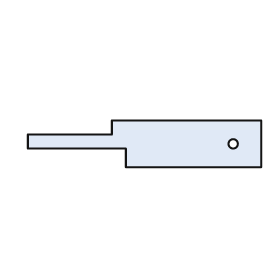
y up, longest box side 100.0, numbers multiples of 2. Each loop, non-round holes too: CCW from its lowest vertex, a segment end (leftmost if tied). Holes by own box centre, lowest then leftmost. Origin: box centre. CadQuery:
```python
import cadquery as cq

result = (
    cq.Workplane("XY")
    .moveTo(-8.0, -10.0)
    .lineTo(50.0, -10.0)
    .lineTo(50.0, 10.0)
    .lineTo(-14.0, 10.0)
    .lineTo(-14.0, 4.0)
    .lineTo(-50.0, 4.0)
    .lineTo(-50.0, -2.0)
    .lineTo(-8.0, -2.0)
    .close()
    .moveTo(38.0, 0.0)
    .circle(2.0)
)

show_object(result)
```